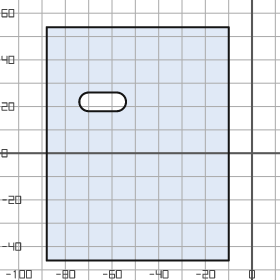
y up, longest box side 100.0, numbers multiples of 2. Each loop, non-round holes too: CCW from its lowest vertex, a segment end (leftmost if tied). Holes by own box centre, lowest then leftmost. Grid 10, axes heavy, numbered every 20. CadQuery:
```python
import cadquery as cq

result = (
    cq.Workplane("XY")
    .moveTo(-88.0, -46.0)
    .lineTo(-10.0, -46.0)
    .lineTo(-10.0, 54.0)
    .lineTo(-88.0, 54.0)
    .close()
    .moveTo(-70.0, 18.0)
    .lineTo(-58.0, 18.0)
    .threePointArc((-54.0, 22.0), (-58.0, 26.0))
    .lineTo(-70.0, 26.0)
    .threePointArc((-74.0, 22.0), (-70.0, 18.0))
    .close()
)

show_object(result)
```